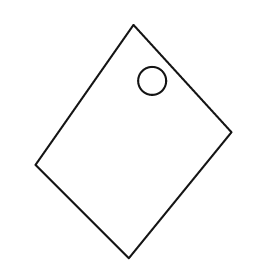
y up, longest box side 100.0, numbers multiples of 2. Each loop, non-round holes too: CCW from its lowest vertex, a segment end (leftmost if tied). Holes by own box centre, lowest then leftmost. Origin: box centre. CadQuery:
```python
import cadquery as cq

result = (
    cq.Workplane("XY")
    .moveTo(-2.0, -50.0)
    .lineTo(42.0, 4.0)
    .lineTo(0.0, 50.0)
    .lineTo(-42.0, -10.0)
    .close()
    .moveTo(8.0, 26.0)
    .circle(6.0)
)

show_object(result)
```